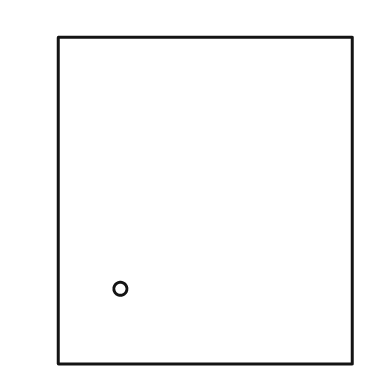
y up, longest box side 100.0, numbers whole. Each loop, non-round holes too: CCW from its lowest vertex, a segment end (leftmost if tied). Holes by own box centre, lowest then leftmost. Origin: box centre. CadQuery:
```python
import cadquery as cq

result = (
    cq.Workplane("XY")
    .moveTo(-45.0, -50.0)
    .lineTo(45.0, -50.0)
    .lineTo(45.0, 50.0)
    .lineTo(-45.0, 50.0)
    .close()
    .moveTo(-26.0, -27.0)
    .circle(2.0)
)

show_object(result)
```